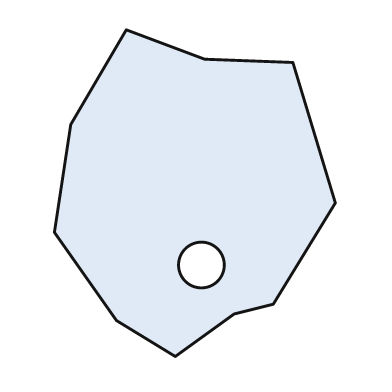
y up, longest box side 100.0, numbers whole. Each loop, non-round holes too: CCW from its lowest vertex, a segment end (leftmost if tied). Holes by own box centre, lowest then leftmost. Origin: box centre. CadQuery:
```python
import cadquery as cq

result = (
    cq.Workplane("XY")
    .moveTo(-6.0, -50.0)
    .lineTo(12.0, -37.0)
    .lineTo(24.0, -34.0)
    .lineTo(43.0, -3.0)
    .lineTo(30.0, 40.0)
    .lineTo(3.0, 41.0)
    .lineTo(-21.0, 50.0)
    .lineTo(-38.0, 21.0)
    .lineTo(-43.0, -12.0)
    .lineTo(-24.0, -39.0)
    .close()
    .moveTo(2.0, -22.0)
    .circle(7.0)
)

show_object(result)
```